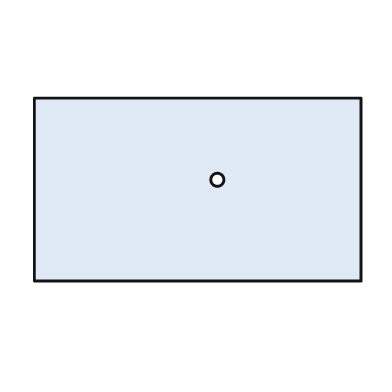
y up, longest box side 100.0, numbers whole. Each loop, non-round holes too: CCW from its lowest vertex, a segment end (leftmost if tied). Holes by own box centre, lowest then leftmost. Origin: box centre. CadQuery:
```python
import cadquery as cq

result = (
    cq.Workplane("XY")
    .moveTo(-50.0, -28.0)
    .lineTo(50.0, -28.0)
    .lineTo(50.0, 28.0)
    .lineTo(-50.0, 28.0)
    .close()
    .moveTo(6.0, 3.0)
    .circle(2.0)
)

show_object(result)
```